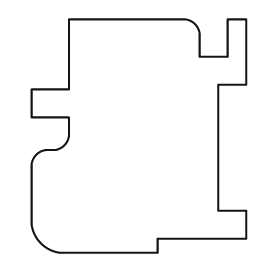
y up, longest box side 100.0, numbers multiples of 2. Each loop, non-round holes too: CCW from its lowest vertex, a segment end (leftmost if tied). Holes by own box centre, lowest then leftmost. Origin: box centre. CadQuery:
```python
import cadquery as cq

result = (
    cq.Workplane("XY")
    .moveTo(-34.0, -50.0)
    .lineTo(8.0, -50.0)
    .lineTo(8.0, -44.0)
    .lineTo(46.0, -44.0)
    .lineTo(46.0, -32.0)
    .lineTo(34.0, -32.0)
    .lineTo(34.0, 22.0)
    .lineTo(46.0, 22.0)
    .lineTo(46.0, 50.0)
    .lineTo(38.0, 50.0)
    .lineTo(38.0, 34.0)
    .lineTo(26.0, 34.0)
    .lineTo(26.0, 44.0)
    .threePointArc((24.0, 48.0), (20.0, 50.0))
    .lineTo(-30.0, 50.0)
    .lineTo(-30.0, 20.0)
    .lineTo(-46.0, 20.0)
    .lineTo(-46.0, 8.0)
    .lineTo(-30.0, 8.0)
    .lineTo(-30.0, 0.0)
    .threePointArc((-32.0, -4.0), (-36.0, -6.0))
    .lineTo(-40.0, -6.0)
    .threePointArc((-44.0, -8.0), (-46.0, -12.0))
    .lineTo(-46.0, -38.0)
    .threePointArc((-42.0, -46.0), (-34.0, -50.0))
    .close()
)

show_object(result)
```